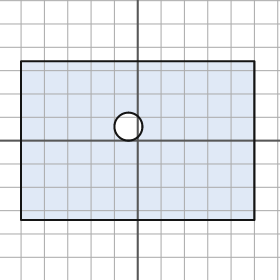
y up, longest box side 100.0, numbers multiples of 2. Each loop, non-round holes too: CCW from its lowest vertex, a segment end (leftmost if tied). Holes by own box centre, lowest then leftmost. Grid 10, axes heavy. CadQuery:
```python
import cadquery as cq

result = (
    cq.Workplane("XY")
    .moveTo(-50.0, -34.0)
    .lineTo(50.0, -34.0)
    .lineTo(50.0, 34.0)
    .lineTo(-50.0, 34.0)
    .close()
    .moveTo(-4.0, 6.0)
    .circle(6.0)
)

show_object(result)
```